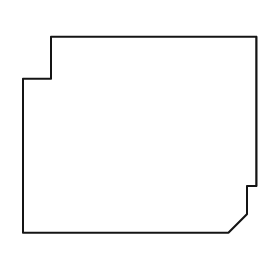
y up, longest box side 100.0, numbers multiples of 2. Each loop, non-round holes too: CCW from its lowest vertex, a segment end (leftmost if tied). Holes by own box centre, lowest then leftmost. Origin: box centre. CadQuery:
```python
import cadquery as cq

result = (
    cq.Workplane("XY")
    .moveTo(-50.0, -42.0)
    .lineTo(38.0, -42.0)
    .lineTo(46.0, -34.0)
    .lineTo(46.0, -22.0)
    .lineTo(50.0, -22.0)
    .lineTo(50.0, 42.0)
    .lineTo(-38.0, 42.0)
    .lineTo(-38.0, 24.0)
    .lineTo(-50.0, 24.0)
    .close()
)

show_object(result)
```